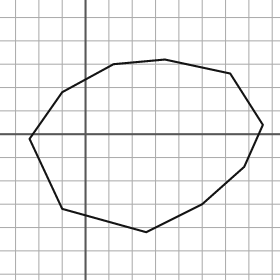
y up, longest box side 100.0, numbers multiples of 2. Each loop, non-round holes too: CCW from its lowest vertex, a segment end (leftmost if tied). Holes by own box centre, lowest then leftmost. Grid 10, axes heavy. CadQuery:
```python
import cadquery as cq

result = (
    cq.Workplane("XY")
    .moveTo(26.0, -42.0)
    .lineTo(50.0, -30.0)
    .lineTo(68.0, -14.0)
    .lineTo(76.0, 4.0)
    .lineTo(62.0, 26.0)
    .lineTo(34.0, 32.0)
    .lineTo(12.0, 30.0)
    .lineTo(-10.0, 18.0)
    .lineTo(-24.0, -2.0)
    .lineTo(-10.0, -32.0)
    .close()
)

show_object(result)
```